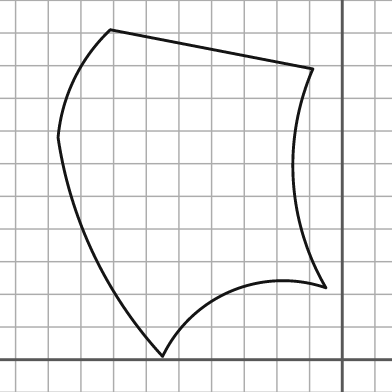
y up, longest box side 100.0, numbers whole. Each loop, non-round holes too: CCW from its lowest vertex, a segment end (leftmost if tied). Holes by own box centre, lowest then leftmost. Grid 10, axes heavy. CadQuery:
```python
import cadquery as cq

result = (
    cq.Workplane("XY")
    .moveTo(-55.0, 1.0)
    .threePointArc((-34.0, 21.0), (-5.0, 22.0))
    .threePointArc((-15.0, 55.0), (-9.0, 89.0))
    .lineTo(-71.0, 101.0)
    .threePointArc((-82.0, 86.0), (-87.0, 68.0))
    .threePointArc((-76.0, 32.0), (-55.0, 1.0))
    .close()
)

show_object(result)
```